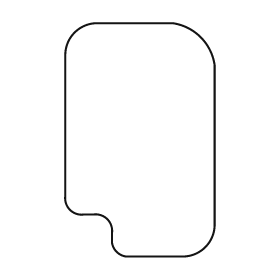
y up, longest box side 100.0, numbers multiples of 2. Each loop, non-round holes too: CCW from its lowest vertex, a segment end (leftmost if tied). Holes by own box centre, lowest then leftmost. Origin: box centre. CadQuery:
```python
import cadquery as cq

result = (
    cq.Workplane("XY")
    .moveTo(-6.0, -50.0)
    .lineTo(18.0, -50.0)
    .threePointArc((28.0, -46.0), (32.0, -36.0))
    .lineTo(32.0, 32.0)
    .threePointArc((26.0, 44.0), (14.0, 50.0))
    .lineTo(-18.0, 50.0)
    .threePointArc((-28.0, 46.0), (-32.0, 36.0))
    .lineTo(-32.0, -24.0)
    .threePointArc((-30.0, -30.0), (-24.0, -32.0))
    .lineTo(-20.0, -32.0)
    .threePointArc((-14.0, -34.0), (-12.0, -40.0))
    .lineTo(-12.0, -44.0)
    .threePointArc((-10.0, -48.0), (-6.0, -50.0))
    .close()
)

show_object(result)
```